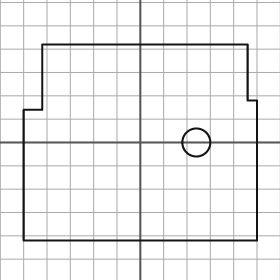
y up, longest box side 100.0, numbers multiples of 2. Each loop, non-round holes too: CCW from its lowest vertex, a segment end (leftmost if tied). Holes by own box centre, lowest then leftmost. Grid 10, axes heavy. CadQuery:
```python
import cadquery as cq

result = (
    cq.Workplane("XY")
    .moveTo(-50.0, -42.0)
    .lineTo(50.0, -42.0)
    .lineTo(50.0, 18.0)
    .lineTo(46.0, 18.0)
    .lineTo(46.0, 42.0)
    .lineTo(-42.0, 42.0)
    .lineTo(-42.0, 14.0)
    .lineTo(-50.0, 14.0)
    .close()
    .moveTo(24.0, 0.0)
    .circle(6.0)
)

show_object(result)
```